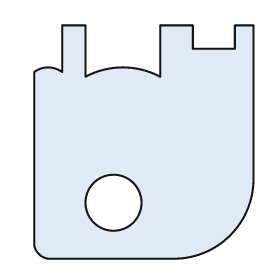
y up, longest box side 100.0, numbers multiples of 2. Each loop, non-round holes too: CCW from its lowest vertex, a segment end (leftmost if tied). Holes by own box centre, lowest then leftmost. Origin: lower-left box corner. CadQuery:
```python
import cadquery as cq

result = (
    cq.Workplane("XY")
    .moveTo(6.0, 0.0)
    .lineTo(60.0, 0.0)
    .threePointArc((84.0, 10.0), (94.0, 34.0))
    .lineTo(94.0, 100.0)
    .lineTo(86.0, 100.0)
    .lineTo(86.0, 90.0)
    .lineTo(68.0, 90.0)
    .lineTo(68.0, 100.0)
    .lineTo(54.0, 100.0)
    .lineTo(54.0, 78.0)
    .threePointArc((38.0, 82.0), (22.0, 78.0))
    .lineTo(22.0, 100.0)
    .lineTo(12.0, 100.0)
    .lineTo(12.0, 80.0)
    .threePointArc((6.0, 82.0), (0.0, 80.0))
    .lineTo(0.0, 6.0)
    .threePointArc((2.0, 2.0), (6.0, 0.0))
    .close()
    .moveTo(34.0, 24.0)
    .circle(12.0)
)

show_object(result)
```